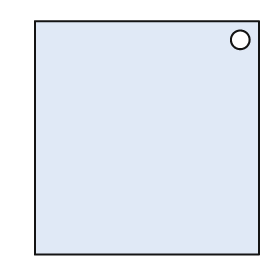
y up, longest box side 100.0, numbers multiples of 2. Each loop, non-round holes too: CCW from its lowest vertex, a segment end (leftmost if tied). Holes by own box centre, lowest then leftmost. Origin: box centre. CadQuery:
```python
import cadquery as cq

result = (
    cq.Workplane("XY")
    .moveTo(-48.0, -50.0)
    .lineTo(48.0, -50.0)
    .lineTo(48.0, 50.0)
    .lineTo(-48.0, 50.0)
    .close()
    .moveTo(40.0, 42.0)
    .circle(4.0)
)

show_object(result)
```